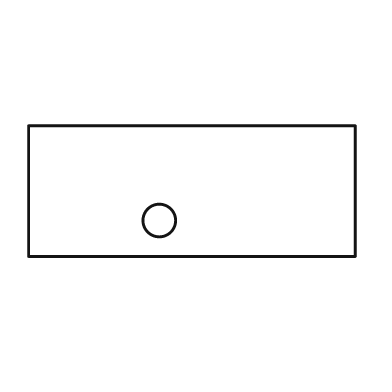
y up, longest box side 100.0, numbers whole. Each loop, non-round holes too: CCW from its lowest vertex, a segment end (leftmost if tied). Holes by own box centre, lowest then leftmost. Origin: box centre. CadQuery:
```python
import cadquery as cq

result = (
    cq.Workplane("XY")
    .moveTo(-50.0, -20.0)
    .lineTo(50.0, -20.0)
    .lineTo(50.0, 20.0)
    .lineTo(-50.0, 20.0)
    .close()
    .moveTo(-10.0, -9.0)
    .circle(5.0)
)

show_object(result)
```